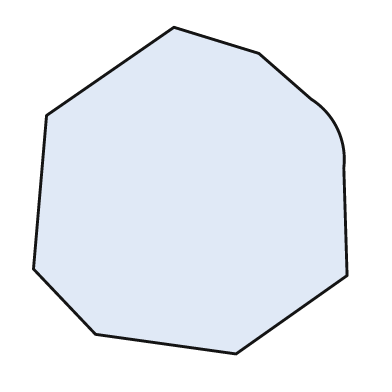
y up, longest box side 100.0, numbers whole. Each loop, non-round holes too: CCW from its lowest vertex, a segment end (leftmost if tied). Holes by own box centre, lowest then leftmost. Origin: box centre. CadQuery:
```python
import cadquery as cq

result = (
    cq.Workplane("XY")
    .moveTo(14.0, -50.0)
    .lineTo(48.0, -26.0)
    .lineTo(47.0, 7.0)
    .threePointArc((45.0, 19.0), (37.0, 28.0))
    .lineTo(21.0, 42.0)
    .lineTo(-5.0, 50.0)
    .lineTo(-44.0, 23.0)
    .lineTo(-48.0, -24.0)
    .lineTo(-29.0, -44.0)
    .close()
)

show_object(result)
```